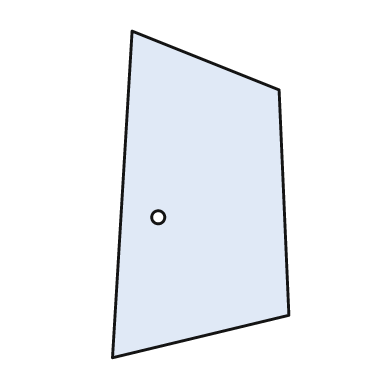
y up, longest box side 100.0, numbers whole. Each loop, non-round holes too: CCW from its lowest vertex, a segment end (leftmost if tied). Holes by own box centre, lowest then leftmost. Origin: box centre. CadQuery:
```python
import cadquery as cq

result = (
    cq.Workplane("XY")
    .moveTo(-27.0, -50.0)
    .lineTo(27.0, -37.0)
    .lineTo(24.0, 32.0)
    .lineTo(-21.0, 50.0)
    .close()
    .moveTo(-13.0, -7.0)
    .circle(2.0)
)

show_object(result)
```